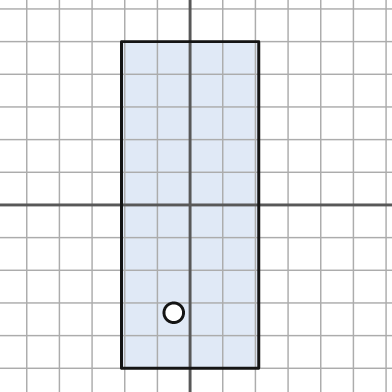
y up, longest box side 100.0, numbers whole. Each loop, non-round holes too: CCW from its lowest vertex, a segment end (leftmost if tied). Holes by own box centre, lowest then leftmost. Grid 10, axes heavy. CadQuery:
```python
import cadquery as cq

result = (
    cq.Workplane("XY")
    .moveTo(-21.0, -50.0)
    .lineTo(21.0, -50.0)
    .lineTo(21.0, 50.0)
    .lineTo(-21.0, 50.0)
    .close()
    .moveTo(-5.0, -33.0)
    .circle(3.0)
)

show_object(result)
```